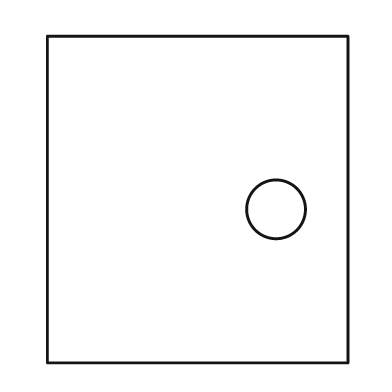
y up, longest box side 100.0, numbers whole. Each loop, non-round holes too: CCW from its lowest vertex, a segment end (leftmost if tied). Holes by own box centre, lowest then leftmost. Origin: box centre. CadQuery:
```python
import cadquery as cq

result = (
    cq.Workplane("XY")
    .moveTo(-46.0, -50.0)
    .lineTo(46.0, -50.0)
    .lineTo(46.0, 50.0)
    .lineTo(-46.0, 50.0)
    .close()
    .moveTo(24.0, -3.0)
    .circle(9.0)
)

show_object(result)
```